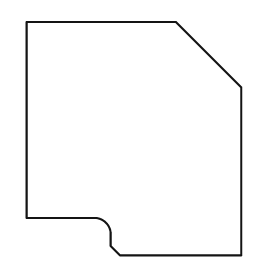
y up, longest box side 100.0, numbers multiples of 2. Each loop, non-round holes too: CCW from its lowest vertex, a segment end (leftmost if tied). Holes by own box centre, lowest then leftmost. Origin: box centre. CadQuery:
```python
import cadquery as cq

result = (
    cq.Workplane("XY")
    .moveTo(-6.0, -50.0)
    .lineTo(46.0, -50.0)
    .lineTo(46.0, 22.0)
    .lineTo(18.0, 50.0)
    .lineTo(-46.0, 50.0)
    .lineTo(-46.0, -34.0)
    .lineTo(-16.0, -34.0)
    .threePointArc((-12.0, -36.0), (-10.0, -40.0))
    .lineTo(-10.0, -46.0)
    .close()
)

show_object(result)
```